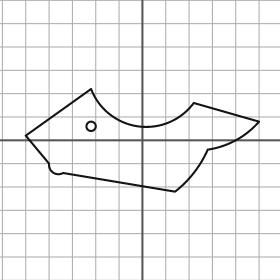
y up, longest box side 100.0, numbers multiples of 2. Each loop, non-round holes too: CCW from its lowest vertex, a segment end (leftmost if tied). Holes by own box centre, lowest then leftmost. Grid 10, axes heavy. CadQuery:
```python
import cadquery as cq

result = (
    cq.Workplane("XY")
    .moveTo(14.0, -22.0)
    .threePointArc((22.0, -14.0), (28.0, -4.0))
    .threePointArc((40.0, 0.0), (50.0, 8.0))
    .lineTo(22.0, 16.0)
    .threePointArc((-2.0, 6.0), (-22.0, 22.0))
    .lineTo(-50.0, 2.0)
    .lineTo(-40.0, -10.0)
    .threePointArc((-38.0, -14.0), (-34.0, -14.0))
    .close()
    .moveTo(-22.0, 6.0)
    .circle(2.0)
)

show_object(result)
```